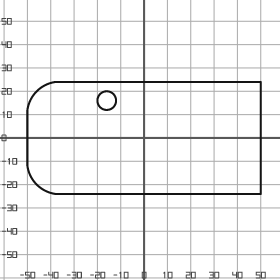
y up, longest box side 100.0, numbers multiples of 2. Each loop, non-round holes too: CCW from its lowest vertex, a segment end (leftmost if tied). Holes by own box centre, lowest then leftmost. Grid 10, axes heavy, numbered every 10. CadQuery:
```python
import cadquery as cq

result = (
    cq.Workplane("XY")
    .moveTo(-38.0, -24.0)
    .lineTo(50.0, -24.0)
    .lineTo(50.0, 24.0)
    .lineTo(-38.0, 24.0)
    .threePointArc((-46.0, 20.0), (-50.0, 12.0))
    .lineTo(-50.0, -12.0)
    .threePointArc((-46.0, -20.0), (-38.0, -24.0))
    .close()
    .moveTo(-16.0, 16.0)
    .circle(4.0)
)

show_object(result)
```